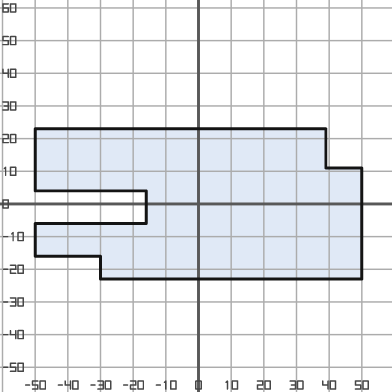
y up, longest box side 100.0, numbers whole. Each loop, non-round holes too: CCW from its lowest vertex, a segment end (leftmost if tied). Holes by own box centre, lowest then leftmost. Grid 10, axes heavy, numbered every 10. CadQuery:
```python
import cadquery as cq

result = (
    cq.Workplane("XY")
    .moveTo(-30.0, -23.0)
    .lineTo(50.0, -23.0)
    .lineTo(50.0, 11.0)
    .lineTo(39.0, 11.0)
    .lineTo(39.0, 23.0)
    .lineTo(-50.0, 23.0)
    .lineTo(-50.0, 4.0)
    .lineTo(-16.0, 4.0)
    .lineTo(-16.0, -6.0)
    .lineTo(-50.0, -6.0)
    .lineTo(-50.0, -16.0)
    .lineTo(-30.0, -16.0)
    .close()
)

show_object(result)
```